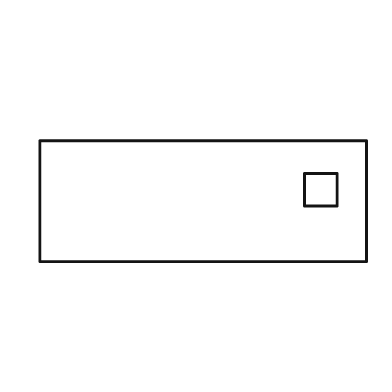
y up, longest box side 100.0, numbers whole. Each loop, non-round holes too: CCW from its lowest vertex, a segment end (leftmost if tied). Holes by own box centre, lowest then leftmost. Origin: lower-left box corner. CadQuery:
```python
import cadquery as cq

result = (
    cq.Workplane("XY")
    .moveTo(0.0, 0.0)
    .lineTo(100.0, 0.0)
    .lineTo(100.0, 37.0)
    .lineTo(0.0, 37.0)
    .close()
    .moveTo(81.0, 17.0)
    .lineTo(91.0, 17.0)
    .lineTo(91.0, 27.0)
    .lineTo(81.0, 27.0)
    .close()
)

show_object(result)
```